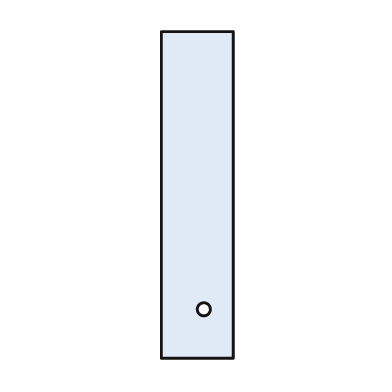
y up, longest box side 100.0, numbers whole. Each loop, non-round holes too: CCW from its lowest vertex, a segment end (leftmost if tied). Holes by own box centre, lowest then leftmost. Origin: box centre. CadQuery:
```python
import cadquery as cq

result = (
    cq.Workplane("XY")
    .moveTo(-11.0, -50.0)
    .lineTo(11.0, -50.0)
    .lineTo(11.0, 50.0)
    .lineTo(-11.0, 50.0)
    .close()
    .moveTo(2.0, -35.0)
    .circle(2.0)
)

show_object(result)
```